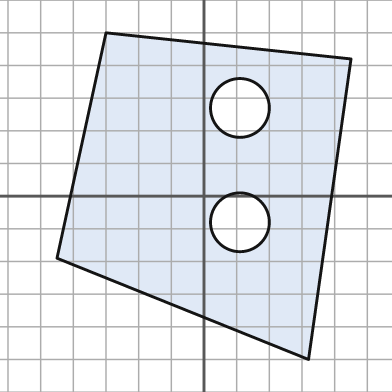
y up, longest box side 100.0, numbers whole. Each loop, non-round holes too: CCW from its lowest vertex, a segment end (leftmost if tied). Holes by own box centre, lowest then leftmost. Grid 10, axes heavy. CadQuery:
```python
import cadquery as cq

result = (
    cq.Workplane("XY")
    .moveTo(32.0, -50.0)
    .lineTo(45.0, 42.0)
    .lineTo(-30.0, 50.0)
    .lineTo(-45.0, -19.0)
    .close()
    .moveTo(11.0, -8.0)
    .circle(9.0)
    .moveTo(11.0, 27.0)
    .circle(9.0)
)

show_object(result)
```